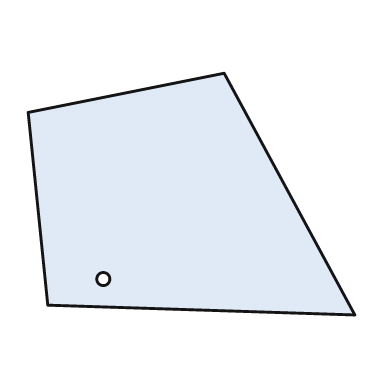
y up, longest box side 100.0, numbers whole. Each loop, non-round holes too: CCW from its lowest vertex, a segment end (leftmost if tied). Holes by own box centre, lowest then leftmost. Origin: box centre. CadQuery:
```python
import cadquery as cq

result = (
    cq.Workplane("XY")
    .moveTo(50.0, -37.0)
    .lineTo(10.0, 37.0)
    .lineTo(-50.0, 25.0)
    .lineTo(-44.0, -34.0)
    .close()
    .moveTo(-27.0, -26.0)
    .circle(2.0)
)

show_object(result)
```